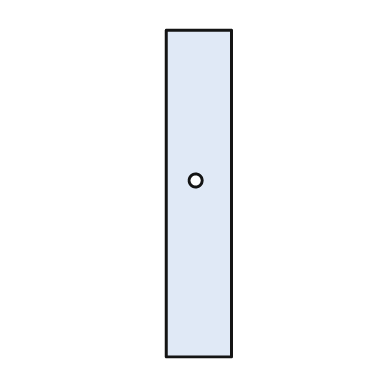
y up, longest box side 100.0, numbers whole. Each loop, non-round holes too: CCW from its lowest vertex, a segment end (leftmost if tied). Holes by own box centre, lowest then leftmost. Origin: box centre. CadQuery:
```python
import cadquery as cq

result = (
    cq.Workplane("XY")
    .moveTo(-10.0, -50.0)
    .lineTo(10.0, -50.0)
    .lineTo(10.0, 50.0)
    .lineTo(-10.0, 50.0)
    .close()
    .moveTo(-1.0, 4.0)
    .circle(2.0)
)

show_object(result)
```